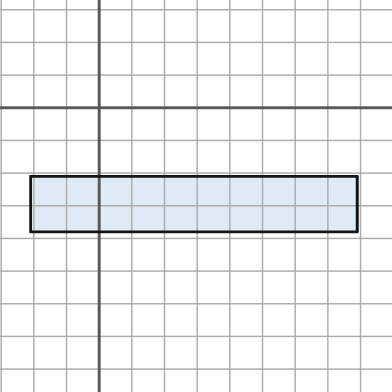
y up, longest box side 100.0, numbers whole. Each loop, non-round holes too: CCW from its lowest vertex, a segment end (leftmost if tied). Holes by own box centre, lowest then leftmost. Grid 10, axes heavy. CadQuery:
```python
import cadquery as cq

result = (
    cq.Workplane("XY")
    .moveTo(-21.0, -38.0)
    .lineTo(79.0, -38.0)
    .lineTo(79.0, -21.0)
    .lineTo(-21.0, -21.0)
    .close()
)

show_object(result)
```